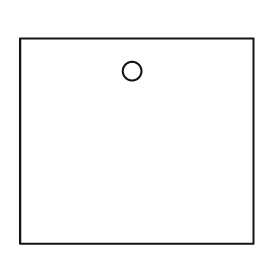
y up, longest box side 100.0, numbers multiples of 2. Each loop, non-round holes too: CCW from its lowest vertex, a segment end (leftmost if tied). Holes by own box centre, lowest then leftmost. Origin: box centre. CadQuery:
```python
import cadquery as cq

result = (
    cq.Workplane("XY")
    .moveTo(-50.0, -44.0)
    .lineTo(50.0, -44.0)
    .lineTo(50.0, 44.0)
    .lineTo(-50.0, 44.0)
    .close()
    .moveTo(-2.0, 30.0)
    .circle(4.0)
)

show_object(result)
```